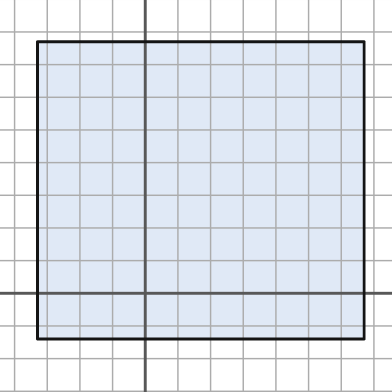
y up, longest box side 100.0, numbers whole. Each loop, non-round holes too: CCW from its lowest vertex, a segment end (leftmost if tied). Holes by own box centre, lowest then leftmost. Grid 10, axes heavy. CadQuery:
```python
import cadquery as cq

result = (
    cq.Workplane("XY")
    .moveTo(-33.0, -14.0)
    .lineTo(67.0, -14.0)
    .lineTo(67.0, 77.0)
    .lineTo(-33.0, 77.0)
    .close()
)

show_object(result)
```